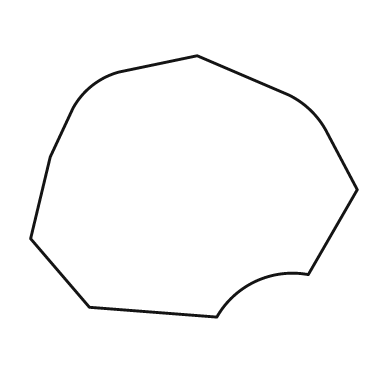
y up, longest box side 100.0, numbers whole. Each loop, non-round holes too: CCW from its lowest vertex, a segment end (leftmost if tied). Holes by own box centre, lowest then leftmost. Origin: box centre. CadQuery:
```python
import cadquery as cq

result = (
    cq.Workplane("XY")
    .moveTo(7.0, -40.0)
    .threePointArc((19.0, -29.0), (35.0, -27.0))
    .lineTo(50.0, -1.0)
    .lineTo(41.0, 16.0)
    .threePointArc((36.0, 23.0), (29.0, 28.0))
    .lineTo(1.0, 40.0)
    .lineTo(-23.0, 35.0)
    .threePointArc((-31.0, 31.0), (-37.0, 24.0))
    .lineTo(-44.0, 9.0)
    .lineTo(-50.0, -16.0)
    .lineTo(-32.0, -37.0)
    .close()
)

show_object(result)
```